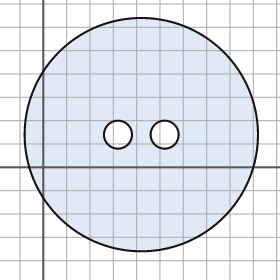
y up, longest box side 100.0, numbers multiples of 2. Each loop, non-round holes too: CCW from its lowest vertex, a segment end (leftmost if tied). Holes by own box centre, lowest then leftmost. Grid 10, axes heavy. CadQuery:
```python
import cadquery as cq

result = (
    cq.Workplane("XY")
    .moveTo(42.0, 14.0)
    .circle(50.0)
    .moveTo(32.0, 14.0)
    .circle(6.0)
    .moveTo(52.0, 14.0)
    .circle(6.0)
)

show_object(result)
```